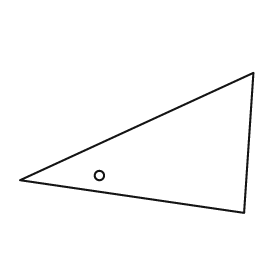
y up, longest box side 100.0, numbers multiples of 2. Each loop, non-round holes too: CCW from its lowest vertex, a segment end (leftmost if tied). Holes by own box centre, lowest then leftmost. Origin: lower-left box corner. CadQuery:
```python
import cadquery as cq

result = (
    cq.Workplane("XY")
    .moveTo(96.0, 0.0)
    .lineTo(100.0, 60.0)
    .lineTo(0.0, 14.0)
    .close()
    .moveTo(34.0, 16.0)
    .circle(2.0)
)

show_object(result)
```